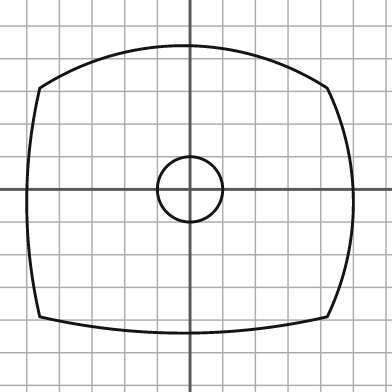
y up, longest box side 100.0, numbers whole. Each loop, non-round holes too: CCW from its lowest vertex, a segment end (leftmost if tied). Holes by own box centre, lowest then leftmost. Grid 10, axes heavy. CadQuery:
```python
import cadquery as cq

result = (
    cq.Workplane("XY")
    .moveTo(-46.0, -39.0)
    .threePointArc((-2.0, -44.0), (42.0, -39.0))
    .threePointArc((50.0, -4.0), (42.0, 31.0))
    .threePointArc((-2.0, 44.0), (-46.0, 31.0))
    .threePointArc((-50.0, -4.0), (-46.0, -39.0))
    .close()
    .moveTo(0.0, 0.0)
    .circle(10.0)
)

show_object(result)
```